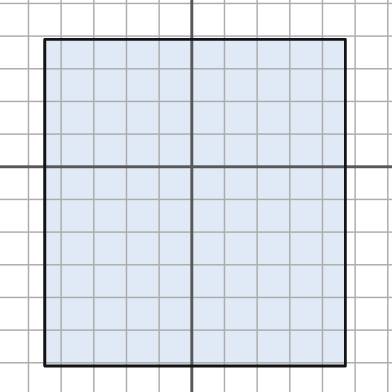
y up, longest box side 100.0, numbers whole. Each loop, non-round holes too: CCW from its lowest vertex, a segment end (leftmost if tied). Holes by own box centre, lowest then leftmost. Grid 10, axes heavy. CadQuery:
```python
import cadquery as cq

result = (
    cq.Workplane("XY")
    .moveTo(-45.0, -61.0)
    .lineTo(47.0, -61.0)
    .lineTo(47.0, 39.0)
    .lineTo(-45.0, 39.0)
    .close()
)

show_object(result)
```